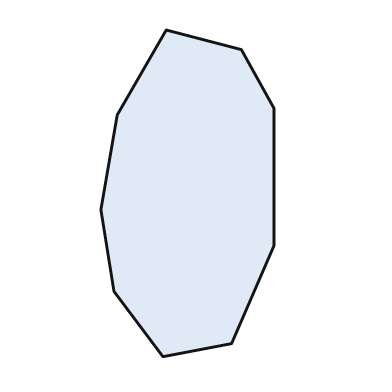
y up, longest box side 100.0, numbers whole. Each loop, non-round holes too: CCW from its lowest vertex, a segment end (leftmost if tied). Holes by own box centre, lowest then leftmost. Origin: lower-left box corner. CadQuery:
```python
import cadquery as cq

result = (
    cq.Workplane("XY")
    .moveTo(19.0, 0.0)
    .lineTo(40.0, 4.0)
    .lineTo(53.0, 34.0)
    .lineTo(53.0, 76.0)
    .lineTo(43.0, 94.0)
    .lineTo(20.0, 100.0)
    .lineTo(5.0, 74.0)
    .lineTo(0.0, 45.0)
    .lineTo(4.0, 20.0)
    .close()
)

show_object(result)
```